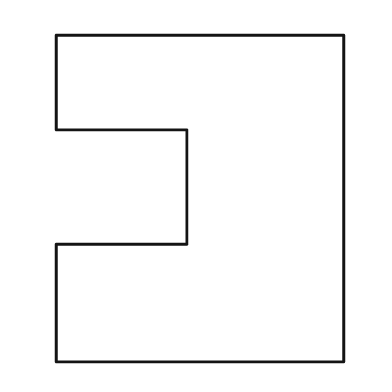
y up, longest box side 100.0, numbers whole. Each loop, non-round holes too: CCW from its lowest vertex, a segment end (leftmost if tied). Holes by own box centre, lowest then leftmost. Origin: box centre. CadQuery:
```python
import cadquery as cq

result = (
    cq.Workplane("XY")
    .moveTo(-44.0, -50.0)
    .lineTo(44.0, -50.0)
    .lineTo(44.0, 50.0)
    .lineTo(-44.0, 50.0)
    .lineTo(-44.0, 21.0)
    .lineTo(-4.0, 21.0)
    .lineTo(-4.0, -14.0)
    .lineTo(-44.0, -14.0)
    .close()
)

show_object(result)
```